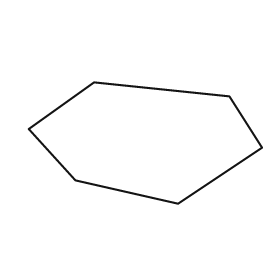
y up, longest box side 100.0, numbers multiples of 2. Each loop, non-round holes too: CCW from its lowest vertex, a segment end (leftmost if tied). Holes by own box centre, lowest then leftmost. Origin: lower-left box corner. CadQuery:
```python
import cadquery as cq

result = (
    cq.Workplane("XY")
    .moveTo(64.0, 0.0)
    .lineTo(100.0, 24.0)
    .lineTo(86.0, 46.0)
    .lineTo(28.0, 52.0)
    .lineTo(0.0, 32.0)
    .lineTo(20.0, 10.0)
    .close()
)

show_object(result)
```